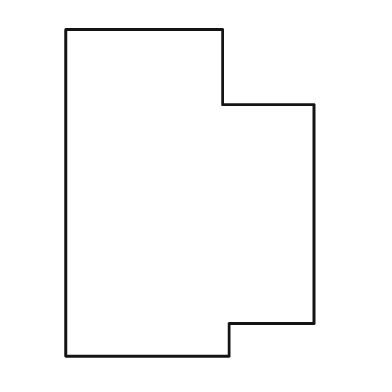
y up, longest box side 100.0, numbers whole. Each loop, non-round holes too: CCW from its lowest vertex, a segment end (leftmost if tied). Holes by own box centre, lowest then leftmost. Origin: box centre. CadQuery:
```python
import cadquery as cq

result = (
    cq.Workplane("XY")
    .moveTo(-38.0, -50.0)
    .lineTo(12.0, -50.0)
    .lineTo(12.0, -40.0)
    .lineTo(38.0, -40.0)
    .lineTo(38.0, 27.0)
    .lineTo(10.0, 27.0)
    .lineTo(10.0, 50.0)
    .lineTo(-38.0, 50.0)
    .close()
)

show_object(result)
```